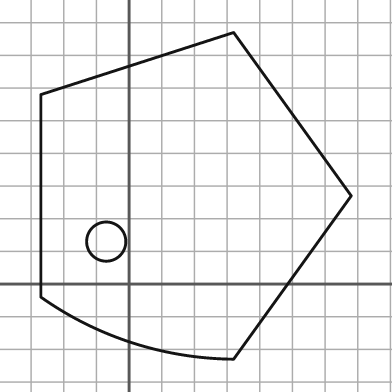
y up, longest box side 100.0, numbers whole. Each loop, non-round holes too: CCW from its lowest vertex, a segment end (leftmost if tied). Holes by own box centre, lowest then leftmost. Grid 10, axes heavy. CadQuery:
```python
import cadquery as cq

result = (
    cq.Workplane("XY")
    .moveTo(32.0, -23.0)
    .lineTo(68.0, 27.0)
    .lineTo(32.0, 77.0)
    .lineTo(-27.0, 58.0)
    .lineTo(-27.0, -4.0)
    .threePointArc((1.0, -18.0), (32.0, -23.0))
    .close()
    .moveTo(-7.0, 13.0)
    .circle(6.0)
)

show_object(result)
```